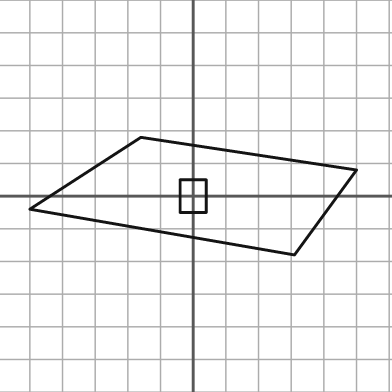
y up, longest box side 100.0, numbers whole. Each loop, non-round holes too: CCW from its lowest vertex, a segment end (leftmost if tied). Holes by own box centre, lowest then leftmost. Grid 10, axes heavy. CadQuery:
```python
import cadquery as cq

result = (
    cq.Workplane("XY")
    .moveTo(31.0, -18.0)
    .lineTo(50.0, 8.0)
    .lineTo(-16.0, 18.0)
    .lineTo(-50.0, -4.0)
    .close()
    .moveTo(-4.0, -5.0)
    .lineTo(4.0, -5.0)
    .lineTo(4.0, 5.0)
    .lineTo(-4.0, 5.0)
    .close()
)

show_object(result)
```